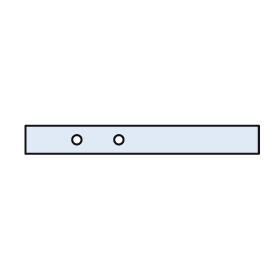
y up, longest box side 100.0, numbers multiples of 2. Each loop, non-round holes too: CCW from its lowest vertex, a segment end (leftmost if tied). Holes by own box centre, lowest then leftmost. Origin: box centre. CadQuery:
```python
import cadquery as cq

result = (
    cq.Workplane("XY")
    .moveTo(-50.0, -6.0)
    .lineTo(50.0, -6.0)
    .lineTo(50.0, 6.0)
    .lineTo(-50.0, 6.0)
    .close()
    .moveTo(-28.0, 0.0)
    .circle(2.0)
    .moveTo(-10.0, 0.0)
    .circle(2.0)
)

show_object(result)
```